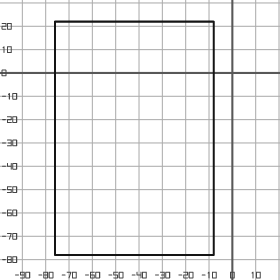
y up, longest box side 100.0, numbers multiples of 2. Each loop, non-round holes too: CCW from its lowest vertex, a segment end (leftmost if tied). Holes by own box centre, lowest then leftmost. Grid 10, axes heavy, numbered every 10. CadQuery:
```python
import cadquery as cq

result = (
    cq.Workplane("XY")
    .moveTo(-76.0, -78.0)
    .lineTo(-8.0, -78.0)
    .lineTo(-8.0, 22.0)
    .lineTo(-76.0, 22.0)
    .close()
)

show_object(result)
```